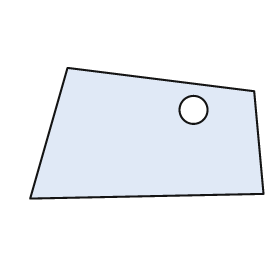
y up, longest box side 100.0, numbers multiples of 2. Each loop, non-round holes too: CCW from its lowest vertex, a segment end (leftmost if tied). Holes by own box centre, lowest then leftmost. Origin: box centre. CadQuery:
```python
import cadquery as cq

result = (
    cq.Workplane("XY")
    .moveTo(-50.0, -28.0)
    .lineTo(50.0, -26.0)
    .lineTo(46.0, 18.0)
    .lineTo(-34.0, 28.0)
    .close()
    .moveTo(20.0, 10.0)
    .circle(6.0)
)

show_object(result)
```